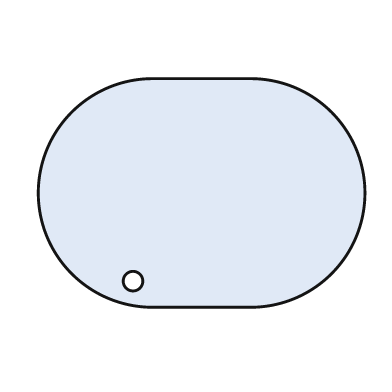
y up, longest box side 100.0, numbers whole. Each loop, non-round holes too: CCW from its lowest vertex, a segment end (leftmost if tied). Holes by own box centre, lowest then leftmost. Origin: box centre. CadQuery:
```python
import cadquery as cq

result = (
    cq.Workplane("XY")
    .moveTo(-15.0, -35.0)
    .lineTo(15.0, -35.0)
    .threePointArc((50.0, 0.0), (15.0, 35.0))
    .lineTo(-15.0, 35.0)
    .threePointArc((-50.0, 0.0), (-15.0, -35.0))
    .close()
    .moveTo(-21.0, -27.0)
    .circle(3.0)
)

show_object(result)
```